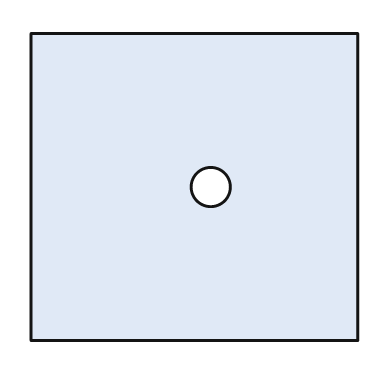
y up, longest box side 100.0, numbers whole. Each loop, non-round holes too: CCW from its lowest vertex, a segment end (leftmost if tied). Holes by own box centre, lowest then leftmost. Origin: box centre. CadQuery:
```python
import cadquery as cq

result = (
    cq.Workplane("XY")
    .moveTo(-50.0, -47.0)
    .lineTo(50.0, -47.0)
    .lineTo(50.0, 47.0)
    .lineTo(-50.0, 47.0)
    .close()
    .moveTo(5.0, 0.0)
    .circle(6.0)
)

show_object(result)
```